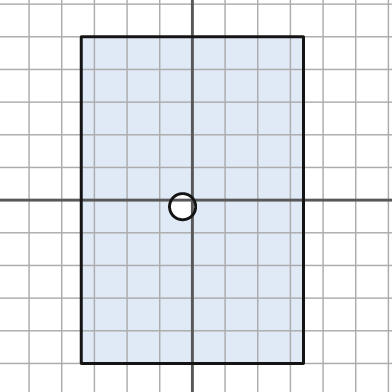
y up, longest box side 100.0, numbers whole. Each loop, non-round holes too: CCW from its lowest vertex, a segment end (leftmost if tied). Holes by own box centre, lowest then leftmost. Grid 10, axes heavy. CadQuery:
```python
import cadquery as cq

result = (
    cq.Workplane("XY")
    .moveTo(-34.0, -50.0)
    .lineTo(34.0, -50.0)
    .lineTo(34.0, 50.0)
    .lineTo(-34.0, 50.0)
    .close()
    .moveTo(-3.0, -2.0)
    .circle(4.0)
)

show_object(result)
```